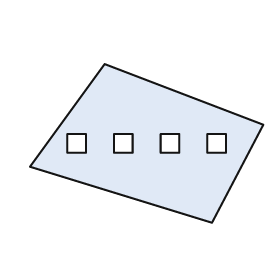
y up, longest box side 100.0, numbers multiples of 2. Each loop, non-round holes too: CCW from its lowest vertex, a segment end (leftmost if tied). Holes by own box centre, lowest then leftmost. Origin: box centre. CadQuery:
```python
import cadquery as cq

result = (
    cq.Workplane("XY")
    .moveTo(28.0, -34.0)
    .lineTo(50.0, 8.0)
    .lineTo(-18.0, 34.0)
    .lineTo(-50.0, -10.0)
    .close()
    .moveTo(-34.0, -4.0)
    .lineTo(-26.0, -4.0)
    .lineTo(-26.0, 4.0)
    .lineTo(-34.0, 4.0)
    .close()
    .moveTo(-14.0, -4.0)
    .lineTo(-6.0, -4.0)
    .lineTo(-6.0, 4.0)
    .lineTo(-14.0, 4.0)
    .close()
    .moveTo(6.0, -4.0)
    .lineTo(14.0, -4.0)
    .lineTo(14.0, 4.0)
    .lineTo(6.0, 4.0)
    .close()
    .moveTo(26.0, -4.0)
    .lineTo(34.0, -4.0)
    .lineTo(34.0, 4.0)
    .lineTo(26.0, 4.0)
    .close()
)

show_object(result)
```